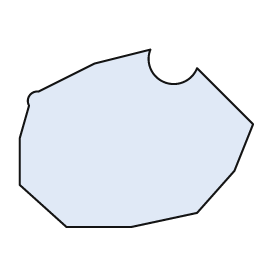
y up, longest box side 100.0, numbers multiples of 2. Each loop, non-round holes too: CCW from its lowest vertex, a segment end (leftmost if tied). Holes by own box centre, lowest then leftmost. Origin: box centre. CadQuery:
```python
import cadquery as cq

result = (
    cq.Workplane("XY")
    .moveTo(-30.0, -38.0)
    .lineTo(-2.0, -38.0)
    .lineTo(26.0, -32.0)
    .lineTo(42.0, -14.0)
    .lineTo(50.0, 6.0)
    .lineTo(26.0, 30.0)
    .threePointArc((12.0, 24.0), (6.0, 38.0))
    .lineTo(-18.0, 32.0)
    .lineTo(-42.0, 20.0)
    .threePointArc((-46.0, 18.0), (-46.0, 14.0))
    .lineTo(-50.0, 0.0)
    .lineTo(-50.0, -20.0)
    .close()
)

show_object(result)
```